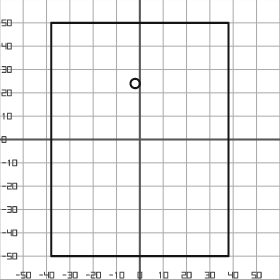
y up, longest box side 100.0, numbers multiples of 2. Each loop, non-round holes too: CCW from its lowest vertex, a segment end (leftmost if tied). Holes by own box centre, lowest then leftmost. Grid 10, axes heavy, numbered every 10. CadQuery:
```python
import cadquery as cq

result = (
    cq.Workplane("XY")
    .moveTo(-38.0, -50.0)
    .lineTo(38.0, -50.0)
    .lineTo(38.0, 50.0)
    .lineTo(-38.0, 50.0)
    .close()
    .moveTo(-2.0, 24.0)
    .circle(2.0)
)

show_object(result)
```